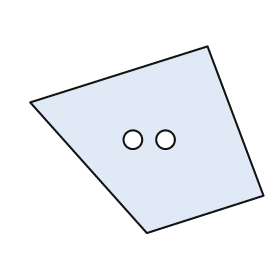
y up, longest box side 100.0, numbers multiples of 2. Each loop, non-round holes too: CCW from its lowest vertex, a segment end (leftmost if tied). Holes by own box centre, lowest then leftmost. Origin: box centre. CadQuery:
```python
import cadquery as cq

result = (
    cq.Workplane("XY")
    .moveTo(0.0, -40.0)
    .lineTo(50.0, -24.0)
    .lineTo(26.0, 40.0)
    .lineTo(-50.0, 16.0)
    .close()
    .moveTo(-6.0, 0.0)
    .circle(4.0)
    .moveTo(8.0, 0.0)
    .circle(4.0)
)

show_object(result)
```